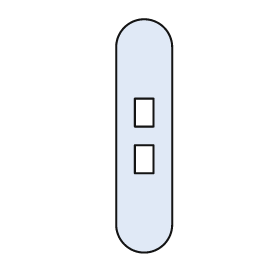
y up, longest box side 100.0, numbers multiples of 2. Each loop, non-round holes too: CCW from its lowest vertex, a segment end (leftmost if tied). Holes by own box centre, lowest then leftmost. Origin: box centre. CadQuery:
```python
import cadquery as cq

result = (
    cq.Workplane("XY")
    .moveTo(-12.0, -38.0)
    .threePointArc((0.0, -50.0), (12.0, -38.0))
    .lineTo(12.0, 38.0)
    .threePointArc((0.0, 50.0), (-12.0, 38.0))
    .close()
    .moveTo(-4.0, -16.0)
    .lineTo(4.0, -16.0)
    .lineTo(4.0, -4.0)
    .lineTo(-4.0, -4.0)
    .close()
    .moveTo(-4.0, 4.0)
    .lineTo(4.0, 4.0)
    .lineTo(4.0, 16.0)
    .lineTo(-4.0, 16.0)
    .close()
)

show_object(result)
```